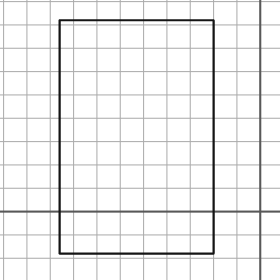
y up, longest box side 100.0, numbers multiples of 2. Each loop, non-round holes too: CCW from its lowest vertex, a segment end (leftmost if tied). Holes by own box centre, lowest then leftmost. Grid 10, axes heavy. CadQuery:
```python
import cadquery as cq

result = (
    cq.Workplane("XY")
    .moveTo(-86.0, -18.0)
    .lineTo(-20.0, -18.0)
    .lineTo(-20.0, 82.0)
    .lineTo(-86.0, 82.0)
    .close()
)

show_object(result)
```